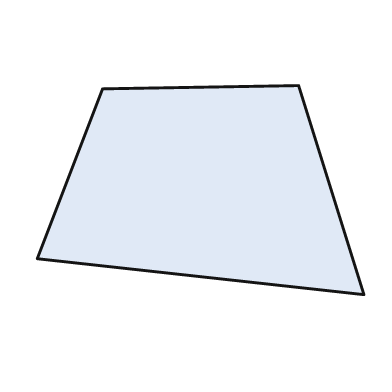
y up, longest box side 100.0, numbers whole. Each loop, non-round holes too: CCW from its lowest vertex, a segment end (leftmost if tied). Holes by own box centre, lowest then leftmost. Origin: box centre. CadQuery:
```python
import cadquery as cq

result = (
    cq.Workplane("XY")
    .moveTo(50.0, -32.0)
    .lineTo(30.0, 32.0)
    .lineTo(-30.0, 31.0)
    .lineTo(-50.0, -21.0)
    .close()
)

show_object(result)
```